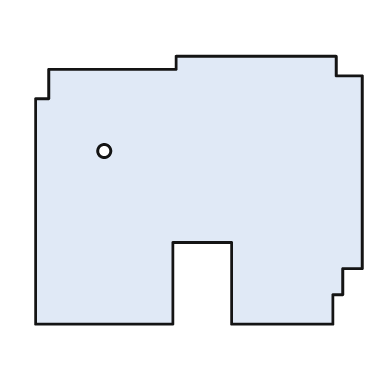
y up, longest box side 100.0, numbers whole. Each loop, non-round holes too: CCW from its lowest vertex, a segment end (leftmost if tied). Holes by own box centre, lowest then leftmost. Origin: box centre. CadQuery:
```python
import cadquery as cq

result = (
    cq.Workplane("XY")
    .moveTo(-50.0, -41.0)
    .lineTo(-8.0, -41.0)
    .lineTo(-8.0, -16.0)
    .lineTo(10.0, -16.0)
    .lineTo(10.0, -41.0)
    .lineTo(41.0, -41.0)
    .lineTo(41.0, -32.0)
    .lineTo(44.0, -32.0)
    .lineTo(44.0, -24.0)
    .lineTo(50.0, -24.0)
    .lineTo(50.0, 35.0)
    .lineTo(42.0, 35.0)
    .lineTo(42.0, 41.0)
    .lineTo(-7.0, 41.0)
    .lineTo(-7.0, 37.0)
    .lineTo(-46.0, 37.0)
    .lineTo(-46.0, 28.0)
    .lineTo(-50.0, 28.0)
    .close()
    .moveTo(-29.0, 12.0)
    .circle(2.0)
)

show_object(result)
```